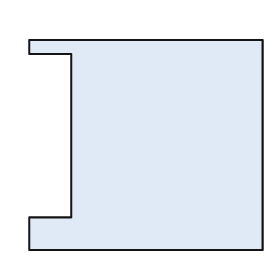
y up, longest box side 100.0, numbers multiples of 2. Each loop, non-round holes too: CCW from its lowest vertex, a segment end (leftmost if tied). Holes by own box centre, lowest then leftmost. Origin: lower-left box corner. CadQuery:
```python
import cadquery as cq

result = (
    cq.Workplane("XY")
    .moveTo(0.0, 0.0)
    .lineTo(100.0, 0.0)
    .lineTo(100.0, 90.0)
    .lineTo(0.0, 90.0)
    .lineTo(0.0, 84.0)
    .lineTo(18.0, 84.0)
    .lineTo(18.0, 14.0)
    .lineTo(0.0, 14.0)
    .close()
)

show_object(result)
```